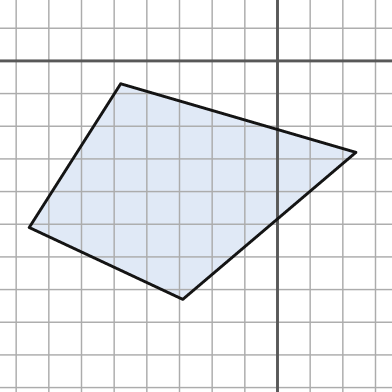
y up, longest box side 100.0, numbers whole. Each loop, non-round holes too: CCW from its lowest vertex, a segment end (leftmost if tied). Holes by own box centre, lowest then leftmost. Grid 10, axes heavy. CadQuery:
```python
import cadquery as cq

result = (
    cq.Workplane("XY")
    .moveTo(-29.0, -73.0)
    .lineTo(24.0, -28.0)
    .lineTo(-48.0, -7.0)
    .lineTo(-76.0, -51.0)
    .close()
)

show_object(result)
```